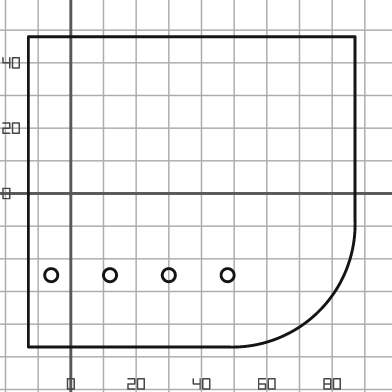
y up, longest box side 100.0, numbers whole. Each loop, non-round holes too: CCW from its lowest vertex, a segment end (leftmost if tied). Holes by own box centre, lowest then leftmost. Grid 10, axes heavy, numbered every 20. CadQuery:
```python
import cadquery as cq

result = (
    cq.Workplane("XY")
    .moveTo(-13.0, -47.0)
    .lineTo(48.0, -47.0)
    .threePointArc((76.0, -36.0), (87.0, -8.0))
    .lineTo(87.0, 48.0)
    .lineTo(-13.0, 48.0)
    .close()
    .moveTo(-6.0, -25.0)
    .circle(2.0)
    .moveTo(12.0, -25.0)
    .circle(2.0)
    .moveTo(30.0, -25.0)
    .circle(2.0)
    .moveTo(48.0, -25.0)
    .circle(2.0)
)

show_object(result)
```